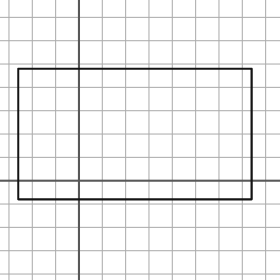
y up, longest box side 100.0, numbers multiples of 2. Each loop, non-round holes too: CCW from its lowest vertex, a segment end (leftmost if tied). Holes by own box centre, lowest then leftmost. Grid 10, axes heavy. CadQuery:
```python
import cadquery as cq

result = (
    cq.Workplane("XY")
    .moveTo(-26.0, -8.0)
    .lineTo(74.0, -8.0)
    .lineTo(74.0, 48.0)
    .lineTo(-26.0, 48.0)
    .close()
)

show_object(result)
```